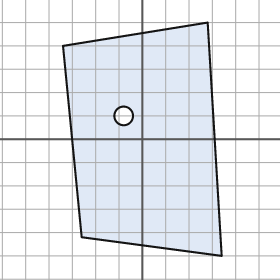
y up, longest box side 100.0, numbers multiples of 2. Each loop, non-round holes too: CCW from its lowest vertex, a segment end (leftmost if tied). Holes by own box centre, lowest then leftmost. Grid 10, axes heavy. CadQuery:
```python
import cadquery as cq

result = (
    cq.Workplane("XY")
    .moveTo(34.0, -50.0)
    .lineTo(28.0, 50.0)
    .lineTo(-34.0, 40.0)
    .lineTo(-26.0, -42.0)
    .close()
    .moveTo(-8.0, 10.0)
    .circle(4.0)
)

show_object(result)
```